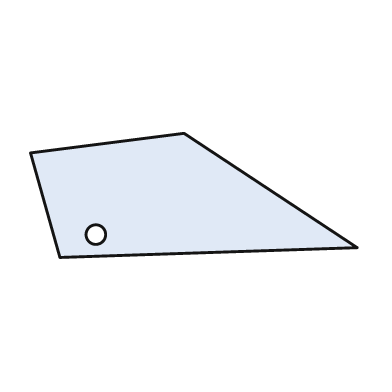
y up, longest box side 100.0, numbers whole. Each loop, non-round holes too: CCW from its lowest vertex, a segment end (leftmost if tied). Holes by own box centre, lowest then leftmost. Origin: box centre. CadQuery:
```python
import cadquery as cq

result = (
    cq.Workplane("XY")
    .moveTo(-41.0, -19.0)
    .lineTo(50.0, -16.0)
    .lineTo(-3.0, 19.0)
    .lineTo(-50.0, 13.0)
    .close()
    .moveTo(-30.0, -12.0)
    .circle(3.0)
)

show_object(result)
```